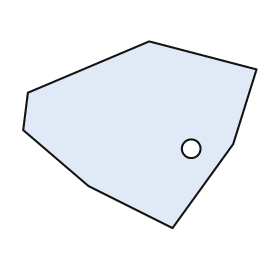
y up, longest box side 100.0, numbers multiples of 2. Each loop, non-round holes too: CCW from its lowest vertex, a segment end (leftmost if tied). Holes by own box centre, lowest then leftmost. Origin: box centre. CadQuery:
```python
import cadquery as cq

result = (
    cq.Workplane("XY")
    .moveTo(14.0, -40.0)
    .lineTo(40.0, -4.0)
    .lineTo(50.0, 28.0)
    .lineTo(4.0, 40.0)
    .lineTo(-48.0, 18.0)
    .lineTo(-50.0, 2.0)
    .lineTo(-22.0, -22.0)
    .close()
    .moveTo(22.0, -6.0)
    .circle(4.0)
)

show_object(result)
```